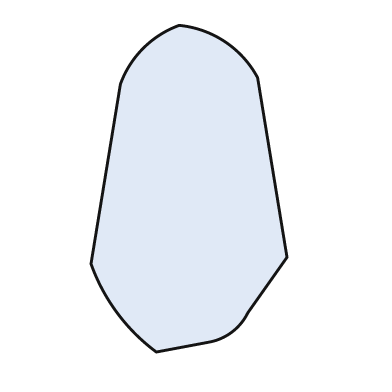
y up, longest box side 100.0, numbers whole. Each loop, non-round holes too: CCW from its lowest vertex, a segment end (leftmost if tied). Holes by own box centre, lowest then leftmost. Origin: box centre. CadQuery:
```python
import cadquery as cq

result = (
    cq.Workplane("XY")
    .moveTo(-10.0, -50.0)
    .lineTo(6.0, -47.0)
    .threePointArc((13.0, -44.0), (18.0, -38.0))
    .lineTo(30.0, -21.0)
    .lineTo(21.0, 34.0)
    .threePointArc((11.0, 45.0), (-3.0, 50.0))
    .threePointArc((-14.0, 43.0), (-21.0, 32.0))
    .lineTo(-30.0, -23.0)
    .threePointArc((-22.0, -38.0), (-10.0, -50.0))
    .close()
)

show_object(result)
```